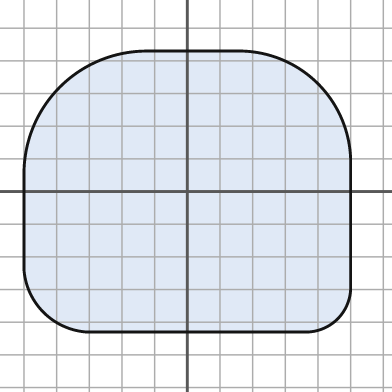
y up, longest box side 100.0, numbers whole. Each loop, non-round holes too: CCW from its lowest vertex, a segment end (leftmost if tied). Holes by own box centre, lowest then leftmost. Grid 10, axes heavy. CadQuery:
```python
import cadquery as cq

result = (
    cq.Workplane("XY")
    .moveTo(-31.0, -43.0)
    .lineTo(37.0, -43.0)
    .threePointArc((46.0, -39.0), (50.0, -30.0))
    .lineTo(50.0, 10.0)
    .threePointArc((40.0, 33.0), (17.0, 43.0))
    .lineTo(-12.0, 43.0)
    .threePointArc((-39.0, 32.0), (-50.0, 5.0))
    .lineTo(-50.0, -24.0)
    .threePointArc((-44.0, -37.0), (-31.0, -43.0))
    .close()
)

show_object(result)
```